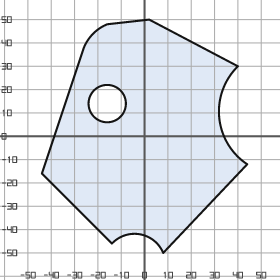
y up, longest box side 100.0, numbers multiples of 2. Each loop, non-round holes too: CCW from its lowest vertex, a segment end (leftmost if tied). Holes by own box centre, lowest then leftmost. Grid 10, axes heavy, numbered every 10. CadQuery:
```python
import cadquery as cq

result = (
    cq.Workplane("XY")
    .moveTo(8.0, -50.0)
    .lineTo(44.0, -12.0)
    .threePointArc((32.0, 8.0), (40.0, 30.0))
    .lineTo(2.0, 50.0)
    .lineTo(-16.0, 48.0)
    .threePointArc((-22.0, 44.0), (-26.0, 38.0))
    .lineTo(-44.0, -16.0)
    .lineTo(-14.0, -46.0)
    .threePointArc((-2.0, -42.0), (8.0, -50.0))
    .close()
    .moveTo(-16.0, 14.0)
    .circle(8.0)
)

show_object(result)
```